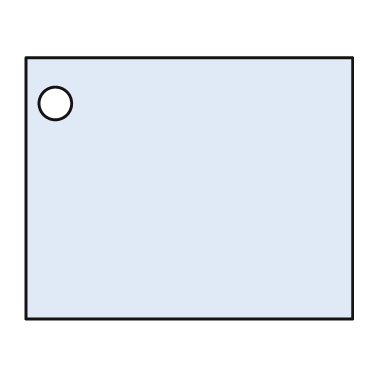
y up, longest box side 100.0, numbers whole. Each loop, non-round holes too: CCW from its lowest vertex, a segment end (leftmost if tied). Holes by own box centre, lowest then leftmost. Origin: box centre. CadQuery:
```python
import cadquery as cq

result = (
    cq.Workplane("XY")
    .moveTo(-50.0, -40.0)
    .lineTo(50.0, -40.0)
    .lineTo(50.0, 40.0)
    .lineTo(-50.0, 40.0)
    .close()
    .moveTo(-41.0, 26.0)
    .circle(5.0)
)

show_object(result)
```